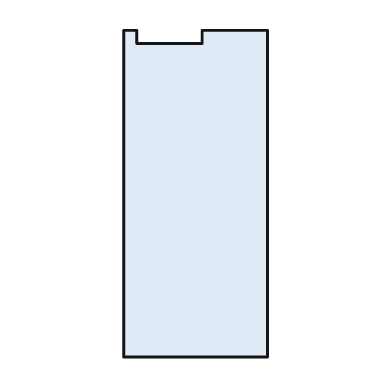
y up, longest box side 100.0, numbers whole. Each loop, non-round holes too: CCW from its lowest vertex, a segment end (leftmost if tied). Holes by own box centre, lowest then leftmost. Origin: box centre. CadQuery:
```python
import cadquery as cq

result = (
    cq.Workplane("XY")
    .moveTo(-22.0, -50.0)
    .lineTo(22.0, -50.0)
    .lineTo(22.0, 50.0)
    .lineTo(2.0, 50.0)
    .lineTo(2.0, 46.0)
    .lineTo(-18.0, 46.0)
    .lineTo(-18.0, 50.0)
    .lineTo(-22.0, 50.0)
    .close()
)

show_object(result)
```